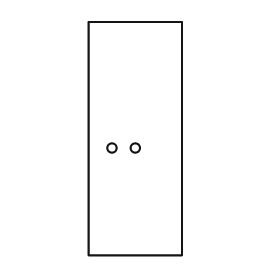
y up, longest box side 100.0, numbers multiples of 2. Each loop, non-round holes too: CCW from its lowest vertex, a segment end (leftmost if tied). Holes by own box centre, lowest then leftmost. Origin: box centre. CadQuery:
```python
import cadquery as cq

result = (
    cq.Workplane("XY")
    .moveTo(-20.0, -50.0)
    .lineTo(20.0, -50.0)
    .lineTo(20.0, 50.0)
    .lineTo(-20.0, 50.0)
    .close()
    .moveTo(-10.0, -4.0)
    .circle(2.0)
    .moveTo(0.0, -4.0)
    .circle(2.0)
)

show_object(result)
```